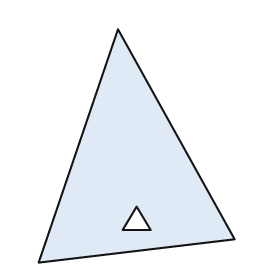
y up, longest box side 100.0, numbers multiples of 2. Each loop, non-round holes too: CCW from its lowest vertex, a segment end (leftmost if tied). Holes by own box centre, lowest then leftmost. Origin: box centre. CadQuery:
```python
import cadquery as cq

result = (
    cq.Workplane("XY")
    .moveTo(-42.0, -50.0)
    .lineTo(42.0, -40.0)
    .lineTo(-8.0, 50.0)
    .close()
    .moveTo(-6.0, -36.0)
    .lineTo(6.0, -36.0)
    .lineTo(0.0, -26.0)
    .close()
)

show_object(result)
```